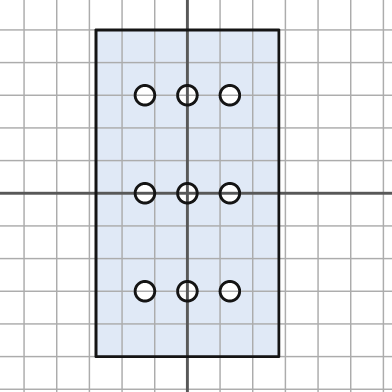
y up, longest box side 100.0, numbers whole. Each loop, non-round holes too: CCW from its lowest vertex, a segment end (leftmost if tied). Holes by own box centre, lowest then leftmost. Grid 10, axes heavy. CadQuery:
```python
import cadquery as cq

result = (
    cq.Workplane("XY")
    .moveTo(-28.0, -50.0)
    .lineTo(28.0, -50.0)
    .lineTo(28.0, 50.0)
    .lineTo(-28.0, 50.0)
    .close()
    .moveTo(-13.0, -30.0)
    .circle(3.0)
    .moveTo(0.0, -30.0)
    .circle(3.0)
    .moveTo(13.0, -30.0)
    .circle(3.0)
    .moveTo(-13.0, 0.0)
    .circle(3.0)
    .moveTo(0.0, 0.0)
    .circle(3.0)
    .moveTo(13.0, 0.0)
    .circle(3.0)
    .moveTo(-13.0, 30.0)
    .circle(3.0)
    .moveTo(0.0, 30.0)
    .circle(3.0)
    .moveTo(13.0, 30.0)
    .circle(3.0)
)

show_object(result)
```